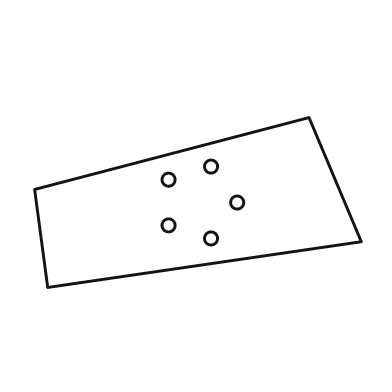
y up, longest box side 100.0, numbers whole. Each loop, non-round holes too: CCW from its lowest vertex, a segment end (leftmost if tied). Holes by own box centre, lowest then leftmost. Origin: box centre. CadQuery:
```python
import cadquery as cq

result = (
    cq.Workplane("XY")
    .moveTo(-46.0, -26.0)
    .lineTo(50.0, -12.0)
    .lineTo(34.0, 26.0)
    .lineTo(-50.0, 4.0)
    .close()
    .moveTo(4.0, -11.0)
    .circle(2.0)
    .moveTo(-9.0, -7.0)
    .circle(2.0)
    .moveTo(12.0, 0.0)
    .circle(2.0)
    .moveTo(-9.0, 7.0)
    .circle(2.0)
    .moveTo(4.0, 11.0)
    .circle(2.0)
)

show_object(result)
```